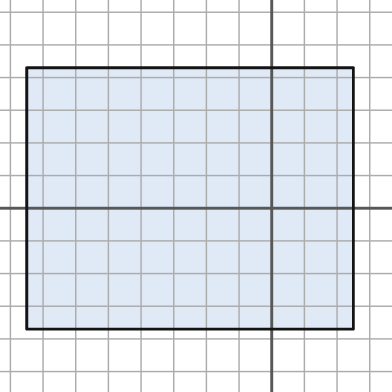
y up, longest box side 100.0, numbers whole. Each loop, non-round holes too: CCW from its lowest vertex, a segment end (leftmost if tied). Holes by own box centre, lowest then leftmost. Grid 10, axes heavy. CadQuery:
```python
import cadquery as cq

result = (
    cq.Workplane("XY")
    .moveTo(-75.0, -37.0)
    .lineTo(25.0, -37.0)
    .lineTo(25.0, 43.0)
    .lineTo(-75.0, 43.0)
    .close()
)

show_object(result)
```